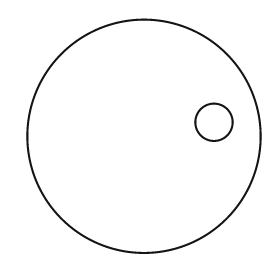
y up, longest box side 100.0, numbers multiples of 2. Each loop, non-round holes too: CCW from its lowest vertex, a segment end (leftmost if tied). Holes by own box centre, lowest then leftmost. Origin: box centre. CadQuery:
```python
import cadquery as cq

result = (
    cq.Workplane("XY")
    .moveTo(0.0, 0.0)
    .circle(50.0)
    .moveTo(30.0, 6.0)
    .circle(8.0)
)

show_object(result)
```